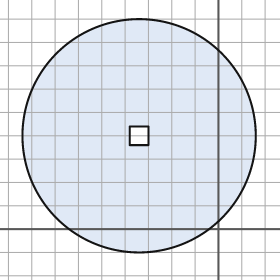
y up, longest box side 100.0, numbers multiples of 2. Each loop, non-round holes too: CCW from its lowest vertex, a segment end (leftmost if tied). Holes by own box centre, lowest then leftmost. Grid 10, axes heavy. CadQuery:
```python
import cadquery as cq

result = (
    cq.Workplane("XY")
    .moveTo(-34.0, 40.0)
    .circle(50.0)
    .moveTo(-38.0, 36.0)
    .lineTo(-30.0, 36.0)
    .lineTo(-30.0, 44.0)
    .lineTo(-38.0, 44.0)
    .close()
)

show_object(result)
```